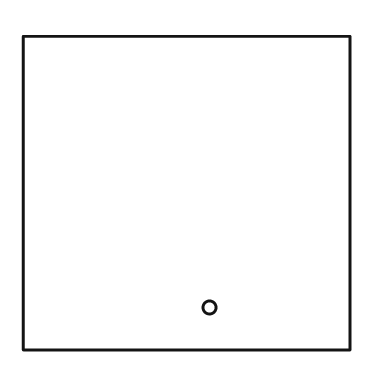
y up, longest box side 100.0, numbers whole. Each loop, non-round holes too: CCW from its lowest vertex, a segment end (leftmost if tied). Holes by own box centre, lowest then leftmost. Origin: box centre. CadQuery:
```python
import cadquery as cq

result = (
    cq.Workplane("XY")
    .moveTo(-50.0, -48.0)
    .lineTo(50.0, -48.0)
    .lineTo(50.0, 48.0)
    .lineTo(-50.0, 48.0)
    .close()
    .moveTo(7.0, -35.0)
    .circle(2.0)
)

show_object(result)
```